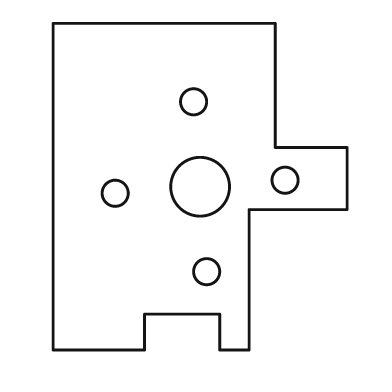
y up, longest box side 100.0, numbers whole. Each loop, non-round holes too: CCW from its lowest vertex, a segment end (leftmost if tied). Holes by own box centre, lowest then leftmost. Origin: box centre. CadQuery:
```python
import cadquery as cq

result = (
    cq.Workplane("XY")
    .moveTo(-45.0, -50.0)
    .lineTo(-17.0, -50.0)
    .lineTo(-17.0, -39.0)
    .lineTo(6.0, -39.0)
    .lineTo(6.0, -50.0)
    .lineTo(15.0, -50.0)
    .lineTo(15.0, -7.0)
    .lineTo(45.0, -7.0)
    .lineTo(45.0, 12.0)
    .lineTo(23.0, 12.0)
    .lineTo(23.0, 50.0)
    .lineTo(-45.0, 50.0)
    .close()
    .moveTo(2.0, -26.0)
    .circle(4.0)
    .moveTo(-26.0, -2.0)
    .circle(4.0)
    .moveTo(0.0, 0.0)
    .circle(9.0)
    .moveTo(26.0, 2.0)
    .circle(4.0)
    .moveTo(-2.0, 26.0)
    .circle(4.0)
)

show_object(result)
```